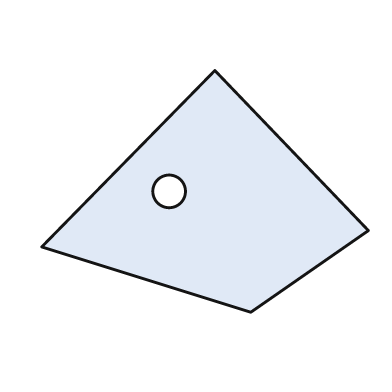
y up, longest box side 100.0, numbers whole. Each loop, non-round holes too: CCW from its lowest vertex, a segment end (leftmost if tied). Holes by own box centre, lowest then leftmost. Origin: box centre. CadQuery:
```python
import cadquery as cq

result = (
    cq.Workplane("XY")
    .moveTo(14.0, -37.0)
    .lineTo(50.0, -12.0)
    .lineTo(3.0, 37.0)
    .lineTo(-50.0, -17.0)
    .close()
    .moveTo(-11.0, 0.0)
    .circle(5.0)
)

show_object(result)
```